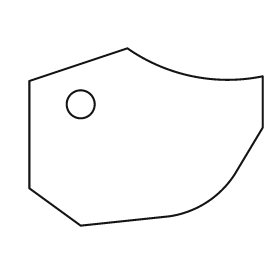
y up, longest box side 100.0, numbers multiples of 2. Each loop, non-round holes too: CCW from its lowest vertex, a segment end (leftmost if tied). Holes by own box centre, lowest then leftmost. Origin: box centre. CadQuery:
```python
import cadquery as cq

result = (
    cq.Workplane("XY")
    .moveTo(-28.0, -38.0)
    .lineTo(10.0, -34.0)
    .threePointArc((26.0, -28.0), (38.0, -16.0))
    .lineTo(50.0, 4.0)
    .lineTo(50.0, 26.0)
    .threePointArc((20.0, 26.0), (-8.0, 38.0))
    .lineTo(-50.0, 24.0)
    .lineTo(-50.0, -22.0)
    .close()
    .moveTo(-28.0, 14.0)
    .circle(6.0)
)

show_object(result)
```